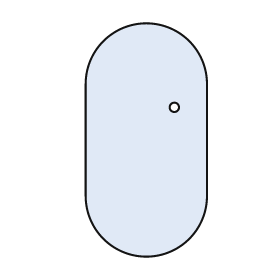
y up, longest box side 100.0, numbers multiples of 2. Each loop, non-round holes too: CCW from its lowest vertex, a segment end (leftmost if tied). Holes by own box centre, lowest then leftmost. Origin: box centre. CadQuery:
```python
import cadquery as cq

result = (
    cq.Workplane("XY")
    .moveTo(-26.0, -24.0)
    .threePointArc((0.0, -50.0), (26.0, -24.0))
    .lineTo(26.0, 24.0)
    .threePointArc((0.0, 50.0), (-26.0, 24.0))
    .close()
    .moveTo(12.0, 14.0)
    .circle(2.0)
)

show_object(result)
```